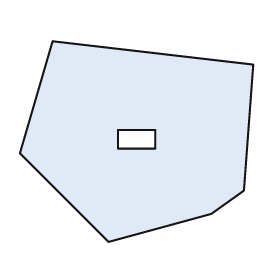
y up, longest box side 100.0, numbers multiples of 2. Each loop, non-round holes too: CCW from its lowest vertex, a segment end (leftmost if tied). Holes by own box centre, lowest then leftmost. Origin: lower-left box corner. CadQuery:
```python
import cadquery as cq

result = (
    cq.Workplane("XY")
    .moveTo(38.0, 0.0)
    .lineTo(82.0, 12.0)
    .lineTo(96.0, 22.0)
    .lineTo(100.0, 76.0)
    .lineTo(14.0, 86.0)
    .lineTo(0.0, 38.0)
    .close()
    .moveTo(42.0, 40.0)
    .lineTo(58.0, 40.0)
    .lineTo(58.0, 48.0)
    .lineTo(42.0, 48.0)
    .close()
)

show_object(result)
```